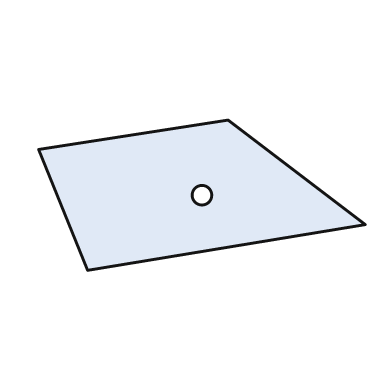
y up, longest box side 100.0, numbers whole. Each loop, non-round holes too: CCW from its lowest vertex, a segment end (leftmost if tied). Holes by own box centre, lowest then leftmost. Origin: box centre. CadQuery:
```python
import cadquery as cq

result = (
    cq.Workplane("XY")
    .moveTo(-35.0, -23.0)
    .lineTo(50.0, -9.0)
    .lineTo(8.0, 23.0)
    .lineTo(-50.0, 14.0)
    .close()
    .moveTo(0.0, 0.0)
    .circle(3.0)
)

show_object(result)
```